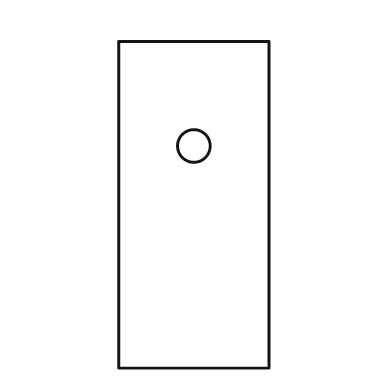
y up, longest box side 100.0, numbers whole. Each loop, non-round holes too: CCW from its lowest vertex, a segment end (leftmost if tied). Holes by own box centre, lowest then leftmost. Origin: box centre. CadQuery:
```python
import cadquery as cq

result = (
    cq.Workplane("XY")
    .moveTo(-23.0, -50.0)
    .lineTo(23.0, -50.0)
    .lineTo(23.0, 50.0)
    .lineTo(-23.0, 50.0)
    .close()
    .moveTo(0.0, 18.0)
    .circle(5.0)
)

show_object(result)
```